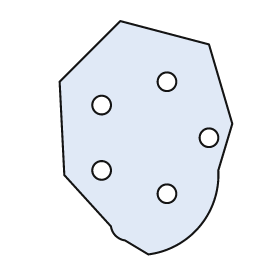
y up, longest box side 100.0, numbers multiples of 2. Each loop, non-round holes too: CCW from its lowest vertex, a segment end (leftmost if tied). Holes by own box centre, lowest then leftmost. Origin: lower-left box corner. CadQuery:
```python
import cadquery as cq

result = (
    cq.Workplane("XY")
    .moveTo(38.0, 0.0)
    .threePointArc((60.0, 12.0), (68.0, 36.0))
    .lineTo(74.0, 56.0)
    .lineTo(64.0, 90.0)
    .lineTo(26.0, 100.0)
    .lineTo(0.0, 74.0)
    .lineTo(2.0, 34.0)
    .lineTo(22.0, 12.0)
    .threePointArc((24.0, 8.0), (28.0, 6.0))
    .close()
    .moveTo(46.0, 26.0)
    .circle(4.0)
    .moveTo(18.0, 36.0)
    .circle(4.0)
    .moveTo(64.0, 50.0)
    .circle(4.0)
    .moveTo(18.0, 64.0)
    .circle(4.0)
    .moveTo(46.0, 74.0)
    .circle(4.0)
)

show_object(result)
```